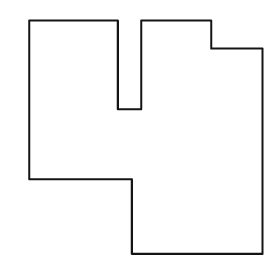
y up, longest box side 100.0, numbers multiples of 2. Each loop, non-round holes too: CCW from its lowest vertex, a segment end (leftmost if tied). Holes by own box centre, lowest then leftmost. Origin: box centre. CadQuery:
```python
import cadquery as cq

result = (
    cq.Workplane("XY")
    .moveTo(-6.0, -50.0)
    .lineTo(50.0, -50.0)
    .lineTo(50.0, 38.0)
    .lineTo(28.0, 38.0)
    .lineTo(28.0, 50.0)
    .lineTo(-2.0, 50.0)
    .lineTo(-2.0, 12.0)
    .lineTo(-12.0, 12.0)
    .lineTo(-12.0, 50.0)
    .lineTo(-50.0, 50.0)
    .lineTo(-50.0, -18.0)
    .lineTo(-6.0, -18.0)
    .close()
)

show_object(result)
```